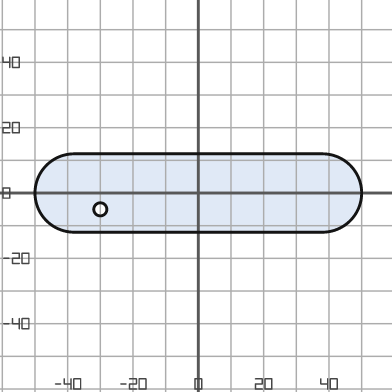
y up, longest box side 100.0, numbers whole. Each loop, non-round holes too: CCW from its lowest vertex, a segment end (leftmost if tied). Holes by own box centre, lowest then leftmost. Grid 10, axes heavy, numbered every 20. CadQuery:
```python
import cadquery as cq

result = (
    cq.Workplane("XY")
    .moveTo(-38.0, -12.0)
    .lineTo(38.0, -12.0)
    .threePointArc((50.0, 0.0), (38.0, 12.0))
    .lineTo(-38.0, 12.0)
    .threePointArc((-50.0, 0.0), (-38.0, -12.0))
    .close()
    .moveTo(-30.0, -5.0)
    .circle(2.0)
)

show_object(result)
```